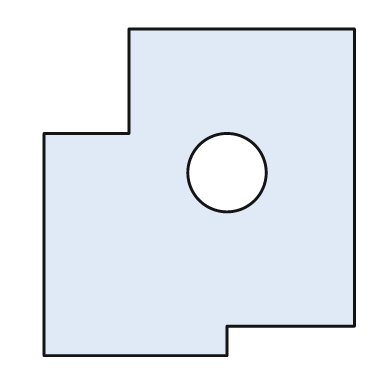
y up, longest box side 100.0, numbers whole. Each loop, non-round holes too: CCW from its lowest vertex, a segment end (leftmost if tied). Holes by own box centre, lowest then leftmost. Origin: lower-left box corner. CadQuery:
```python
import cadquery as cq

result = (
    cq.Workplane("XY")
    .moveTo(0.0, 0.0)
    .lineTo(56.0, 0.0)
    .lineTo(56.0, 9.0)
    .lineTo(95.0, 9.0)
    .lineTo(95.0, 100.0)
    .lineTo(26.0, 100.0)
    .lineTo(26.0, 68.0)
    .lineTo(0.0, 68.0)
    .close()
    .moveTo(56.0, 56.0)
    .circle(12.0)
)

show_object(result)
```